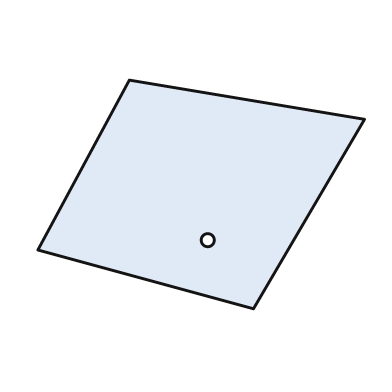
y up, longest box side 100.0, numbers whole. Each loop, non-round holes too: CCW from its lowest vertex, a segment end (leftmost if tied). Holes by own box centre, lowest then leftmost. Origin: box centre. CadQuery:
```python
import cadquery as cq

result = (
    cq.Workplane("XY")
    .moveTo(16.0, -35.0)
    .lineTo(50.0, 23.0)
    .lineTo(-22.0, 35.0)
    .lineTo(-50.0, -17.0)
    .close()
    .moveTo(2.0, -14.0)
    .circle(2.0)
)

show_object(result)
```